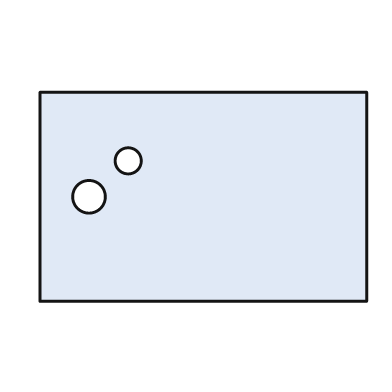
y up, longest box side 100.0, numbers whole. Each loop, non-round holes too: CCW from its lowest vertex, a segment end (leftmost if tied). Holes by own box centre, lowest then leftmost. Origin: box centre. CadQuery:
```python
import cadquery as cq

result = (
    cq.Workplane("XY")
    .moveTo(-50.0, -32.0)
    .lineTo(50.0, -32.0)
    .lineTo(50.0, 32.0)
    .lineTo(-50.0, 32.0)
    .close()
    .moveTo(-35.0, 0.0)
    .circle(5.0)
    .moveTo(-23.0, 11.0)
    .circle(4.0)
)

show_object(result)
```